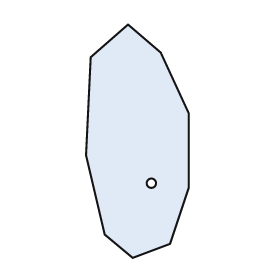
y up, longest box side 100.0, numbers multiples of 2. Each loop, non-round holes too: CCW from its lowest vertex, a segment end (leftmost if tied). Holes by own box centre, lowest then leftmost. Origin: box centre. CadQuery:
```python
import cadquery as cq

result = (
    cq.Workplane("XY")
    .moveTo(-2.0, -50.0)
    .lineTo(14.0, -44.0)
    .lineTo(22.0, -20.0)
    .lineTo(22.0, 12.0)
    .lineTo(10.0, 38.0)
    .lineTo(-4.0, 50.0)
    .lineTo(-20.0, 36.0)
    .lineTo(-22.0, -6.0)
    .lineTo(-14.0, -40.0)
    .close()
    .moveTo(6.0, -18.0)
    .circle(2.0)
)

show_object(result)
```